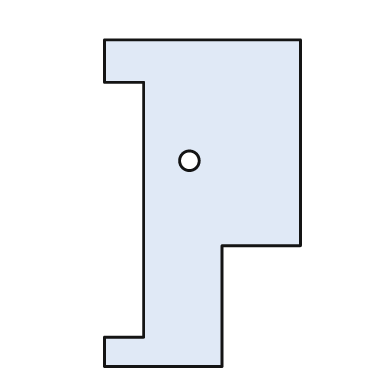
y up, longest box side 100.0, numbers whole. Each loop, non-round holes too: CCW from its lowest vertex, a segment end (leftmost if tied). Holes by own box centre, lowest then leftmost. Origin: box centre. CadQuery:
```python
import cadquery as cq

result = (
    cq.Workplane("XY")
    .moveTo(-30.0, -50.0)
    .lineTo(6.0, -50.0)
    .lineTo(6.0, -13.0)
    .lineTo(30.0, -13.0)
    .lineTo(30.0, 50.0)
    .lineTo(-30.0, 50.0)
    .lineTo(-30.0, 37.0)
    .lineTo(-18.0, 37.0)
    .lineTo(-18.0, -41.0)
    .lineTo(-30.0, -41.0)
    .close()
    .moveTo(-4.0, 13.0)
    .circle(3.0)
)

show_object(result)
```